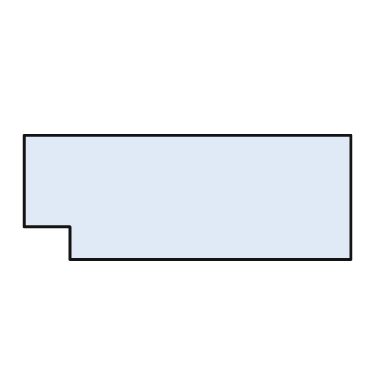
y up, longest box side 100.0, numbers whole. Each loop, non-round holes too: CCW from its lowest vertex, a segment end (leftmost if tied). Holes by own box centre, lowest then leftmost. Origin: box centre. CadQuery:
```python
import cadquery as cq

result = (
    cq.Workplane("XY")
    .moveTo(-36.0, -19.0)
    .lineTo(50.0, -19.0)
    .lineTo(50.0, 19.0)
    .lineTo(-50.0, 19.0)
    .lineTo(-50.0, -9.0)
    .lineTo(-36.0, -9.0)
    .close()
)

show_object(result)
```